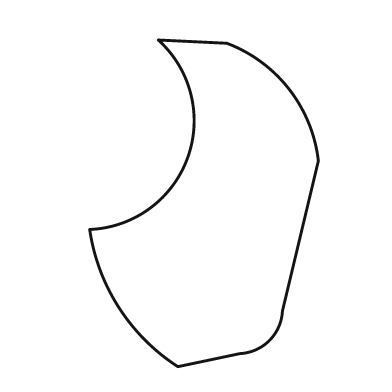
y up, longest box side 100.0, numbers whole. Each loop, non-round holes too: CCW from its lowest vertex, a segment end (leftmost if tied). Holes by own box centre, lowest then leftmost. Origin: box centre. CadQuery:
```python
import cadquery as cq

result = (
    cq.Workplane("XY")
    .moveTo(-8.0, -50.0)
    .lineTo(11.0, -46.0)
    .threePointArc((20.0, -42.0), (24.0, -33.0))
    .lineTo(35.0, 13.0)
    .threePointArc((26.0, 35.0), (7.0, 49.0))
    .lineTo(-14.0, 50.0)
    .threePointArc((-5.0, 14.0), (-35.0, -8.0))
    .threePointArc((-26.0, -32.0), (-8.0, -50.0))
    .close()
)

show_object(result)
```